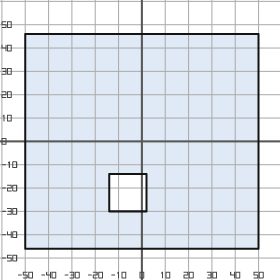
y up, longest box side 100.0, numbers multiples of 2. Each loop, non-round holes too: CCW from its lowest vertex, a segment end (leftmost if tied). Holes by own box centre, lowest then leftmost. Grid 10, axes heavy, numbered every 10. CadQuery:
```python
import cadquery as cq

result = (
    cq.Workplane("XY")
    .moveTo(-50.0, -46.0)
    .lineTo(50.0, -46.0)
    .lineTo(50.0, 46.0)
    .lineTo(-50.0, 46.0)
    .close()
    .moveTo(-14.0, -30.0)
    .lineTo(2.0, -30.0)
    .lineTo(2.0, -14.0)
    .lineTo(-14.0, -14.0)
    .close()
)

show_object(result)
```